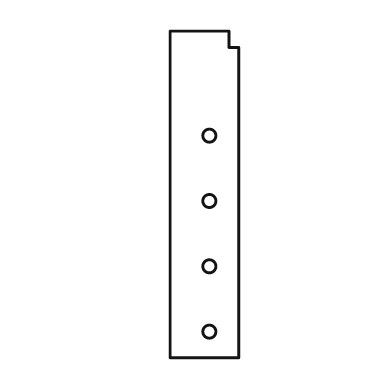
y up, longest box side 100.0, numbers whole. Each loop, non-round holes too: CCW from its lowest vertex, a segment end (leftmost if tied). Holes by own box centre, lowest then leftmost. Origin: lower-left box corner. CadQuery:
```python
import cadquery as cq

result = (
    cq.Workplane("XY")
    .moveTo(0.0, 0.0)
    .lineTo(21.0, 0.0)
    .lineTo(21.0, 95.0)
    .lineTo(18.0, 95.0)
    .lineTo(18.0, 100.0)
    .lineTo(0.0, 100.0)
    .close()
    .moveTo(12.0, 8.0)
    .circle(2.0)
    .moveTo(12.0, 28.0)
    .circle(2.0)
    .moveTo(12.0, 48.0)
    .circle(2.0)
    .moveTo(12.0, 68.0)
    .circle(2.0)
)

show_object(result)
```